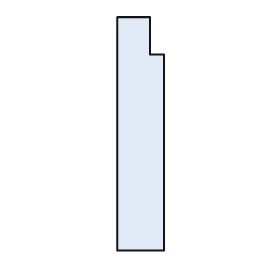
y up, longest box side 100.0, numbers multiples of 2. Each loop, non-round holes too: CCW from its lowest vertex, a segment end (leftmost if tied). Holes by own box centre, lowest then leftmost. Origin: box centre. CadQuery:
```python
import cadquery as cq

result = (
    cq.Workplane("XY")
    .moveTo(-10.0, -50.0)
    .lineTo(10.0, -50.0)
    .lineTo(10.0, 34.0)
    .lineTo(4.0, 34.0)
    .lineTo(4.0, 50.0)
    .lineTo(-10.0, 50.0)
    .close()
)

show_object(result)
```